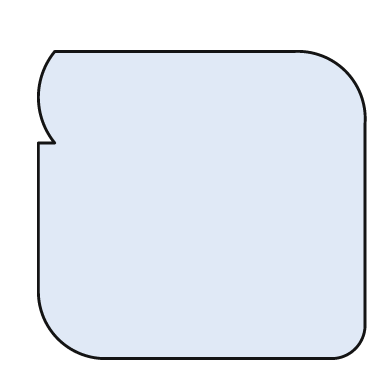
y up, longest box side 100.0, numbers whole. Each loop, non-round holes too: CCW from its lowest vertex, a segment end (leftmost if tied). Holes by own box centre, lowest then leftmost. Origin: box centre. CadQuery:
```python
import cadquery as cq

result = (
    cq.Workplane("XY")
    .moveTo(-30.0, -47.0)
    .lineTo(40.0, -47.0)
    .threePointArc((47.0, -44.0), (50.0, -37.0))
    .lineTo(50.0, 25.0)
    .threePointArc((44.0, 41.0), (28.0, 47.0))
    .lineTo(-45.0, 47.0)
    .threePointArc((-50.0, 33.0), (-45.0, 19.0))
    .lineTo(-50.0, 19.0)
    .lineTo(-50.0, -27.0)
    .threePointArc((-44.0, -41.0), (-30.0, -47.0))
    .close()
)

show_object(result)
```